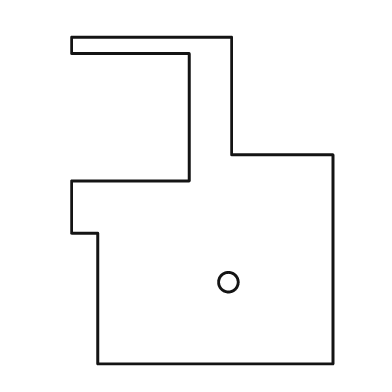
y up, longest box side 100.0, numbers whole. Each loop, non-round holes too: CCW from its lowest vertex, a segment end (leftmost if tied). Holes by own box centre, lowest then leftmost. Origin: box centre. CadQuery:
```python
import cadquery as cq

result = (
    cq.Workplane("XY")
    .moveTo(-32.0, -50.0)
    .lineTo(40.0, -50.0)
    .lineTo(40.0, 14.0)
    .lineTo(9.0, 14.0)
    .lineTo(9.0, 50.0)
    .lineTo(-40.0, 50.0)
    .lineTo(-40.0, 45.0)
    .lineTo(-4.0, 45.0)
    .lineTo(-4.0, 6.0)
    .lineTo(-40.0, 6.0)
    .lineTo(-40.0, -10.0)
    .lineTo(-32.0, -10.0)
    .close()
    .moveTo(8.0, -25.0)
    .circle(3.0)
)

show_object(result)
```